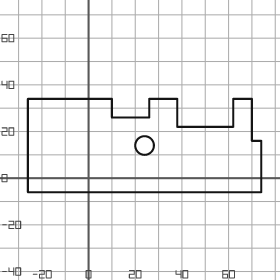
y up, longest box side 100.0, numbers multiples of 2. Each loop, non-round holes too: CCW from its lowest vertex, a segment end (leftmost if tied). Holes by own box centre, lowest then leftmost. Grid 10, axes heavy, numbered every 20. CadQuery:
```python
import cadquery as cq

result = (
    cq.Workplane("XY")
    .moveTo(-26.0, -6.0)
    .lineTo(74.0, -6.0)
    .lineTo(74.0, 16.0)
    .lineTo(70.0, 16.0)
    .lineTo(70.0, 34.0)
    .lineTo(62.0, 34.0)
    .lineTo(62.0, 22.0)
    .lineTo(38.0, 22.0)
    .lineTo(38.0, 34.0)
    .lineTo(26.0, 34.0)
    .lineTo(26.0, 26.0)
    .lineTo(10.0, 26.0)
    .lineTo(10.0, 34.0)
    .lineTo(-26.0, 34.0)
    .close()
    .moveTo(24.0, 14.0)
    .circle(4.0)
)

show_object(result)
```